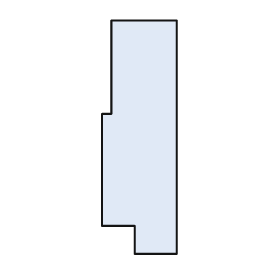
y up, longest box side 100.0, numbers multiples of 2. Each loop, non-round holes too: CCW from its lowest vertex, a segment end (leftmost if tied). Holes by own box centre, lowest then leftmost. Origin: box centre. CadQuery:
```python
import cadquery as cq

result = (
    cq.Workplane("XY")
    .moveTo(-2.0, -50.0)
    .lineTo(16.0, -50.0)
    .lineTo(16.0, 50.0)
    .lineTo(-12.0, 50.0)
    .lineTo(-12.0, 10.0)
    .lineTo(-16.0, 10.0)
    .lineTo(-16.0, -38.0)
    .lineTo(-2.0, -38.0)
    .close()
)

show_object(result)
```